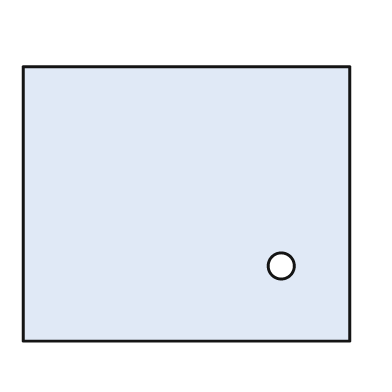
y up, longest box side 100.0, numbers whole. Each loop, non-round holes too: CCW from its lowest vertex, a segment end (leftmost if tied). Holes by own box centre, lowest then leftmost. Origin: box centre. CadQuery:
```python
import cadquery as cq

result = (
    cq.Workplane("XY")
    .moveTo(-50.0, -42.0)
    .lineTo(50.0, -42.0)
    .lineTo(50.0, 42.0)
    .lineTo(-50.0, 42.0)
    .close()
    .moveTo(29.0, -19.0)
    .circle(4.0)
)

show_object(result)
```